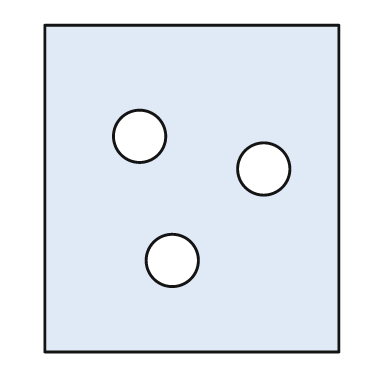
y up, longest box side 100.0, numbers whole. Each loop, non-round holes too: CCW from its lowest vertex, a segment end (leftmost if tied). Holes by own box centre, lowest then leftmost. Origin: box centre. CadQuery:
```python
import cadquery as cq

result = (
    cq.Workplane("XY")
    .moveTo(-45.0, -50.0)
    .lineTo(45.0, -50.0)
    .lineTo(45.0, 50.0)
    .lineTo(-45.0, 50.0)
    .close()
    .moveTo(-6.0, -22.0)
    .circle(8.0)
    .moveTo(22.0, 6.0)
    .circle(8.0)
    .moveTo(-16.0, 16.0)
    .circle(8.0)
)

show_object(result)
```